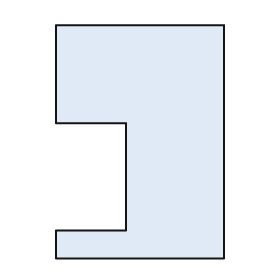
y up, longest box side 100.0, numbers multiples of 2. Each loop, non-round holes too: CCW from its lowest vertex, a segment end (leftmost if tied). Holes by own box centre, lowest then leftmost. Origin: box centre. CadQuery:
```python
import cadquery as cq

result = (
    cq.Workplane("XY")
    .moveTo(-36.0, -50.0)
    .lineTo(36.0, -50.0)
    .lineTo(36.0, 50.0)
    .lineTo(-36.0, 50.0)
    .lineTo(-36.0, 8.0)
    .lineTo(-6.0, 8.0)
    .lineTo(-6.0, -38.0)
    .lineTo(-36.0, -38.0)
    .close()
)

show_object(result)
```